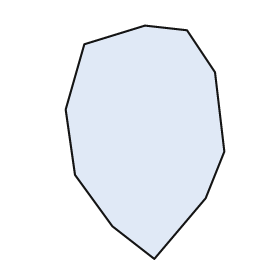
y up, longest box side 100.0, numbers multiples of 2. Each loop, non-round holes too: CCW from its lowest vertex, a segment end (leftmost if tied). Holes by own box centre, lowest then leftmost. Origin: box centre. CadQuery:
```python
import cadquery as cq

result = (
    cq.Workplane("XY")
    .moveTo(4.0, -50.0)
    .lineTo(26.0, -24.0)
    .lineTo(34.0, -4.0)
    .lineTo(30.0, 30.0)
    .lineTo(18.0, 48.0)
    .lineTo(0.0, 50.0)
    .lineTo(-26.0, 42.0)
    .lineTo(-34.0, 14.0)
    .lineTo(-30.0, -14.0)
    .lineTo(-14.0, -36.0)
    .close()
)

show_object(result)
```